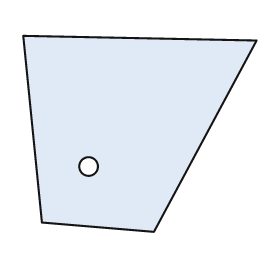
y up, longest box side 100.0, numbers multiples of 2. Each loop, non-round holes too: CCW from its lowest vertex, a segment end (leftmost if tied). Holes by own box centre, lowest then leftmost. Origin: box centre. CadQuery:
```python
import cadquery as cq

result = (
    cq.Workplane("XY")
    .moveTo(6.0, -42.0)
    .lineTo(50.0, 40.0)
    .lineTo(-50.0, 42.0)
    .lineTo(-42.0, -38.0)
    .close()
    .moveTo(-22.0, -14.0)
    .circle(4.0)
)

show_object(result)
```